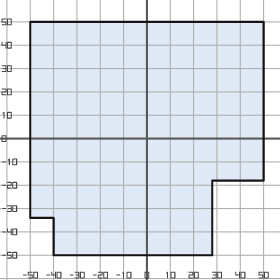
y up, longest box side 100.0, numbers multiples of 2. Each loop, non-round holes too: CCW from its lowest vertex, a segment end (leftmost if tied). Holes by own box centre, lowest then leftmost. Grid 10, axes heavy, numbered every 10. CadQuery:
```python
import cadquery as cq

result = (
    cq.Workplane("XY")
    .moveTo(-40.0, -50.0)
    .lineTo(28.0, -50.0)
    .lineTo(28.0, -18.0)
    .lineTo(50.0, -18.0)
    .lineTo(50.0, 50.0)
    .lineTo(-50.0, 50.0)
    .lineTo(-50.0, -34.0)
    .lineTo(-40.0, -34.0)
    .close()
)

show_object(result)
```